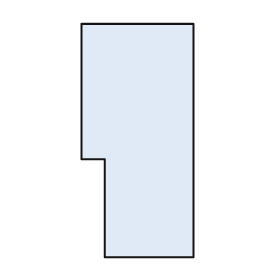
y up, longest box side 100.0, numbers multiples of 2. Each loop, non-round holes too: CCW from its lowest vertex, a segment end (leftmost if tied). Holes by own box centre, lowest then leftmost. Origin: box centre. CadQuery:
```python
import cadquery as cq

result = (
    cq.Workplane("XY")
    .moveTo(-14.0, -50.0)
    .lineTo(24.0, -50.0)
    .lineTo(24.0, 50.0)
    .lineTo(-24.0, 50.0)
    .lineTo(-24.0, -8.0)
    .lineTo(-14.0, -8.0)
    .close()
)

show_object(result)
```